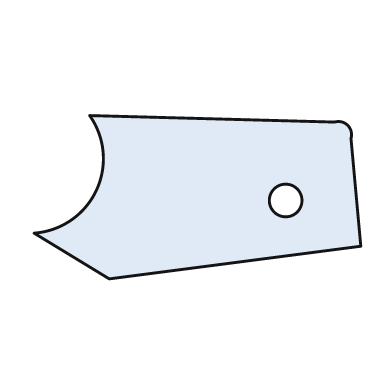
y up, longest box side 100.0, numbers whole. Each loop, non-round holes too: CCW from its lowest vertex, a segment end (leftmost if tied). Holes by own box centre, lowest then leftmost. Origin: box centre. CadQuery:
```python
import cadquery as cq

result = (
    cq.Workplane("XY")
    .moveTo(-27.0, -25.0)
    .lineTo(50.0, -15.0)
    .lineTo(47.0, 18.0)
    .threePointArc((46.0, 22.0), (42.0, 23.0))
    .lineTo(-33.0, 25.0)
    .threePointArc((-31.0, 2.0), (-50.0, -11.0))
    .close()
    .moveTo(27.0, -1.0)
    .circle(5.0)
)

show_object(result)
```